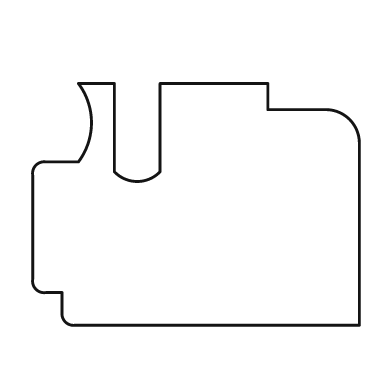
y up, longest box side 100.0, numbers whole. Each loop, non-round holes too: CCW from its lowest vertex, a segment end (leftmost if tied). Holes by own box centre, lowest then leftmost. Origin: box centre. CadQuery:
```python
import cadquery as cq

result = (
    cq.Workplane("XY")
    .moveTo(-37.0, -37.0)
    .lineTo(50.0, -37.0)
    .lineTo(50.0, 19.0)
    .threePointArc((47.0, 26.0), (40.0, 29.0))
    .lineTo(22.0, 29.0)
    .lineTo(22.0, 37.0)
    .lineTo(-11.0, 37.0)
    .lineTo(-11.0, 10.0)
    .threePointArc((-18.0, 7.0), (-25.0, 10.0))
    .lineTo(-25.0, 37.0)
    .lineTo(-36.0, 37.0)
    .threePointArc((-32.0, 25.0), (-36.0, 13.0))
    .lineTo(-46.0, 13.0)
    .threePointArc((-49.0, 12.0), (-50.0, 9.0))
    .lineTo(-50.0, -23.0)
    .threePointArc((-49.0, -26.0), (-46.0, -27.0))
    .lineTo(-41.0, -27.0)
    .lineTo(-41.0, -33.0)
    .threePointArc((-40.0, -36.0), (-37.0, -37.0))
    .close()
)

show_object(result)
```